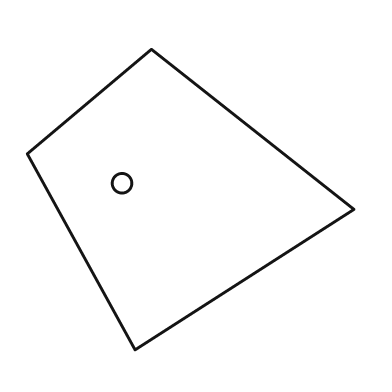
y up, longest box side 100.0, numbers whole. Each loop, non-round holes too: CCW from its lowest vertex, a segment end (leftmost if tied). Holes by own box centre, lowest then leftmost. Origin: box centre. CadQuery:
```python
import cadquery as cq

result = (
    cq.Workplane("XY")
    .moveTo(-17.0, -46.0)
    .lineTo(50.0, -3.0)
    .lineTo(-12.0, 46.0)
    .lineTo(-50.0, 14.0)
    .close()
    .moveTo(-21.0, 5.0)
    .circle(3.0)
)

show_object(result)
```